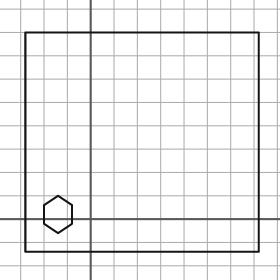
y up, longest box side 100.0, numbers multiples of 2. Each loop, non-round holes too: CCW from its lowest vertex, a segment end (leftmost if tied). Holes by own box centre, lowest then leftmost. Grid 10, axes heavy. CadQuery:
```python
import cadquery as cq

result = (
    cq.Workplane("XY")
    .moveTo(-28.0, -14.0)
    .lineTo(72.0, -14.0)
    .lineTo(72.0, 80.0)
    .lineTo(-28.0, 80.0)
    .close()
    .moveTo(-14.0, -6.0)
    .lineTo(-8.0, -2.0)
    .lineTo(-8.0, 6.0)
    .lineTo(-14.0, 10.0)
    .lineTo(-20.0, 6.0)
    .lineTo(-20.0, -2.0)
    .close()
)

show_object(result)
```